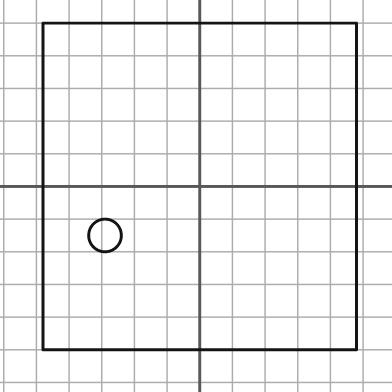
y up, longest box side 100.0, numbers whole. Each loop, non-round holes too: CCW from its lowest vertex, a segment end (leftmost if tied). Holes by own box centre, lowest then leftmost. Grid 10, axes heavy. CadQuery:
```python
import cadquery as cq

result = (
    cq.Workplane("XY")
    .moveTo(-48.0, -50.0)
    .lineTo(48.0, -50.0)
    .lineTo(48.0, 50.0)
    .lineTo(-48.0, 50.0)
    .close()
    .moveTo(-29.0, -15.0)
    .circle(5.0)
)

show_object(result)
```